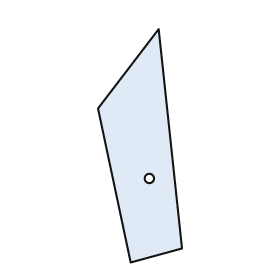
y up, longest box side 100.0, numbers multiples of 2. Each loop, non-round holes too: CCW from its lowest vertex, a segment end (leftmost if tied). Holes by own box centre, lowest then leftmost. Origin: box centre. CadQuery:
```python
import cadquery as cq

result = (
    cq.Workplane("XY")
    .moveTo(-4.0, -50.0)
    .lineTo(18.0, -44.0)
    .lineTo(8.0, 50.0)
    .lineTo(-18.0, 16.0)
    .close()
    .moveTo(4.0, -14.0)
    .circle(2.0)
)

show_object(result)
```